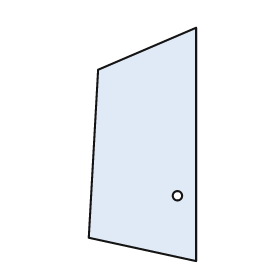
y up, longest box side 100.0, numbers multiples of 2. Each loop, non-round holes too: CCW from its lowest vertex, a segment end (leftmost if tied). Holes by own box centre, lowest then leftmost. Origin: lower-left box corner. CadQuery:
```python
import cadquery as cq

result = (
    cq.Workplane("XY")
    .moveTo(46.0, 0.0)
    .lineTo(46.0, 100.0)
    .lineTo(4.0, 82.0)
    .lineTo(0.0, 10.0)
    .close()
    .moveTo(38.0, 28.0)
    .circle(2.0)
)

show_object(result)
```